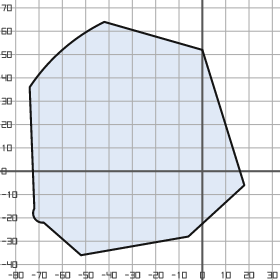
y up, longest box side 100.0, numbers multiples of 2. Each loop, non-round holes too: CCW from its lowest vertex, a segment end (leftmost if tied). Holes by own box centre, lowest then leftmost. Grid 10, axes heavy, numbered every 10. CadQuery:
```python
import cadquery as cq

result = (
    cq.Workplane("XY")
    .moveTo(-52.0, -36.0)
    .lineTo(-6.0, -28.0)
    .lineTo(18.0, -6.0)
    .lineTo(0.0, 52.0)
    .lineTo(-42.0, 64.0)
    .threePointArc((-60.0, 52.0), (-74.0, 36.0))
    .lineTo(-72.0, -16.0)
    .threePointArc((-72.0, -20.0), (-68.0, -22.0))
    .close()
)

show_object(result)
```